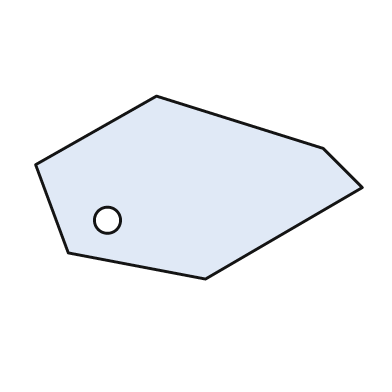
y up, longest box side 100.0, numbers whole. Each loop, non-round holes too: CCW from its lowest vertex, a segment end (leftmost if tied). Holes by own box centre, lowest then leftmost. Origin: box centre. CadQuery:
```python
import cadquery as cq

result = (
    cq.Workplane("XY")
    .moveTo(2.0, -28.0)
    .lineTo(50.0, 0.0)
    .lineTo(38.0, 12.0)
    .lineTo(-13.0, 28.0)
    .lineTo(-50.0, 7.0)
    .lineTo(-40.0, -20.0)
    .close()
    .moveTo(-28.0, -10.0)
    .circle(4.0)
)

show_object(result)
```